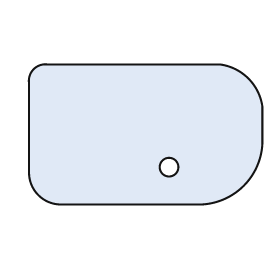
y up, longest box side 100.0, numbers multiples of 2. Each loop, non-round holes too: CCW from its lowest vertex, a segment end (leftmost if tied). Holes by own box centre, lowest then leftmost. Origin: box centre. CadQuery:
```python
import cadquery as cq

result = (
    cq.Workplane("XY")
    .moveTo(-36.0, -30.0)
    .lineTo(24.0, -30.0)
    .threePointArc((42.0, -22.0), (50.0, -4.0))
    .lineTo(50.0, 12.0)
    .threePointArc((44.0, 24.0), (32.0, 30.0))
    .lineTo(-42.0, 30.0)
    .threePointArc((-48.0, 28.0), (-50.0, 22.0))
    .lineTo(-50.0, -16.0)
    .threePointArc((-46.0, -26.0), (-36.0, -30.0))
    .close()
    .moveTo(10.0, -14.0)
    .circle(4.0)
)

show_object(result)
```